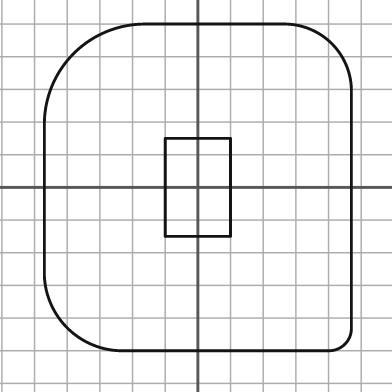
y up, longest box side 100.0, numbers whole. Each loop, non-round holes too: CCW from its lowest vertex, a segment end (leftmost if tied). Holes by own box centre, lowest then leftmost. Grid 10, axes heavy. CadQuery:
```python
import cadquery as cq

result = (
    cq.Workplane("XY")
    .moveTo(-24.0, -50.0)
    .lineTo(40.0, -50.0)
    .threePointArc((45.0, -48.0), (47.0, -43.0))
    .lineTo(47.0, 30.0)
    .threePointArc((41.0, 44.0), (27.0, 50.0))
    .lineTo(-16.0, 50.0)
    .threePointArc((-38.0, 41.0), (-47.0, 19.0))
    .lineTo(-47.0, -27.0)
    .threePointArc((-40.0, -43.0), (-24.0, -50.0))
    .close()
    .moveTo(-10.0, -15.0)
    .lineTo(10.0, -15.0)
    .lineTo(10.0, 15.0)
    .lineTo(-10.0, 15.0)
    .close()
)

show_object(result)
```